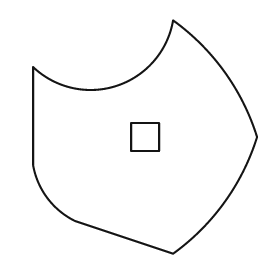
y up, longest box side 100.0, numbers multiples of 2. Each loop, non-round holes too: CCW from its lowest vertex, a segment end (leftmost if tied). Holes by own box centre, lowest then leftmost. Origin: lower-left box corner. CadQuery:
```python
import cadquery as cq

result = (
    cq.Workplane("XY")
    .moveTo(60.0, 0.0)
    .threePointArc((82.0, 22.0), (96.0, 50.0))
    .threePointArc((82.0, 78.0), (60.0, 100.0))
    .threePointArc((36.0, 72.0), (0.0, 80.0))
    .lineTo(0.0, 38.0)
    .threePointArc((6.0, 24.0), (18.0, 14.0))
    .close()
    .moveTo(42.0, 44.0)
    .lineTo(54.0, 44.0)
    .lineTo(54.0, 56.0)
    .lineTo(42.0, 56.0)
    .close()
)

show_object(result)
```